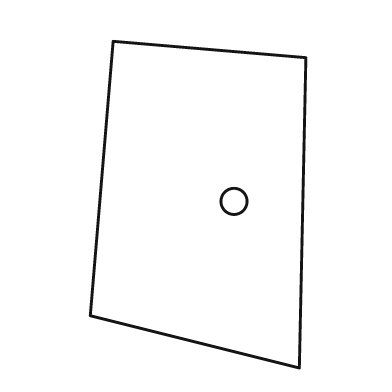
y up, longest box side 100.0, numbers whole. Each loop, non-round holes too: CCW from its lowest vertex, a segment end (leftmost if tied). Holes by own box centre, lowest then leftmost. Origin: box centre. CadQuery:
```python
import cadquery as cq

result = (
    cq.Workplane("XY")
    .moveTo(31.0, -50.0)
    .lineTo(33.0, 45.0)
    .lineTo(-26.0, 50.0)
    .lineTo(-33.0, -34.0)
    .close()
    .moveTo(11.0, 1.0)
    .circle(4.0)
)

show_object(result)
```